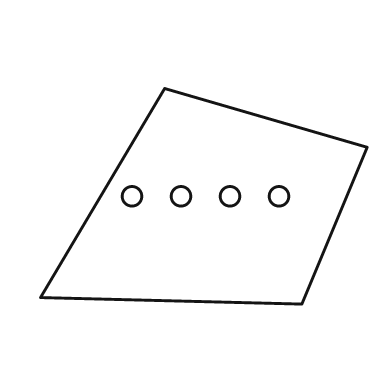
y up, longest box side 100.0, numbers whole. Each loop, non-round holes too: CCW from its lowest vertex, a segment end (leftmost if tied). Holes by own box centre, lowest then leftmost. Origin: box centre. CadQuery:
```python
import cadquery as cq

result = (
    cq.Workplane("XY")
    .moveTo(30.0, -33.0)
    .lineTo(50.0, 15.0)
    .lineTo(-12.0, 33.0)
    .lineTo(-50.0, -31.0)
    .close()
    .moveTo(-22.0, 0.0)
    .circle(3.0)
    .moveTo(-7.0, 0.0)
    .circle(3.0)
    .moveTo(8.0, 0.0)
    .circle(3.0)
    .moveTo(23.0, 0.0)
    .circle(3.0)
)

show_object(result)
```